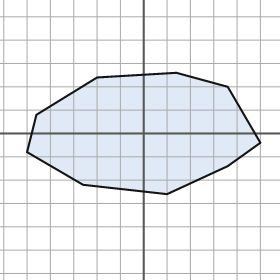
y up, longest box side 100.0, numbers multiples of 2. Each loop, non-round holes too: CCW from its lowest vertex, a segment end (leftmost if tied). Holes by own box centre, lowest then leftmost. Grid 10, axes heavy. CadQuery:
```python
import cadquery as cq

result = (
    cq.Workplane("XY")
    .moveTo(10.0, -26.0)
    .lineTo(36.0, -14.0)
    .lineTo(50.0, -4.0)
    .lineTo(36.0, 20.0)
    .lineTo(14.0, 26.0)
    .lineTo(-20.0, 24.0)
    .lineTo(-46.0, 8.0)
    .lineTo(-50.0, -8.0)
    .lineTo(-26.0, -22.0)
    .close()
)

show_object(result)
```